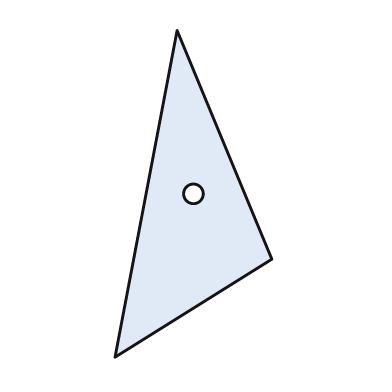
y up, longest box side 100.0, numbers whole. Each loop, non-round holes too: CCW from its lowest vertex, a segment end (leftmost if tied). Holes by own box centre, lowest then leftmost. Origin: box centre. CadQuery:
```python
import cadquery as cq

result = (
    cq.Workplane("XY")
    .moveTo(-24.0, -50.0)
    .lineTo(24.0, -20.0)
    .lineTo(-5.0, 50.0)
    .close()
    .moveTo(0.0, 0.0)
    .circle(3.0)
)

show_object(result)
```